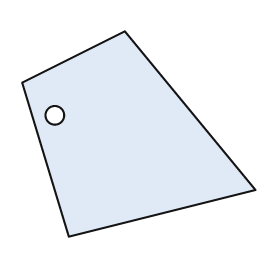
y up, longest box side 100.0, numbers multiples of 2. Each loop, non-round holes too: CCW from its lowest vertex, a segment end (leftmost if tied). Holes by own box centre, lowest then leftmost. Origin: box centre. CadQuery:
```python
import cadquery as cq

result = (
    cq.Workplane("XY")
    .moveTo(-30.0, -44.0)
    .lineTo(50.0, -24.0)
    .lineTo(-6.0, 44.0)
    .lineTo(-50.0, 22.0)
    .close()
    .moveTo(-36.0, 8.0)
    .circle(4.0)
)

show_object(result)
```